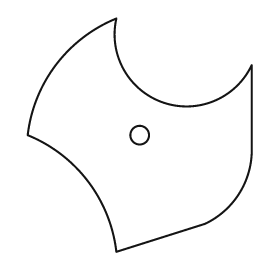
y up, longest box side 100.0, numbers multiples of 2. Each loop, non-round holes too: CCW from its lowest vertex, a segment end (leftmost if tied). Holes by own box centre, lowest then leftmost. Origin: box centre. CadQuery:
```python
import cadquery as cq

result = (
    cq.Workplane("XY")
    .moveTo(-10.0, -50.0)
    .lineTo(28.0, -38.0)
    .threePointArc((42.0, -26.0), (48.0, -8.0))
    .lineTo(48.0, 30.0)
    .threePointArc((10.0, 14.0), (-10.0, 50.0))
    .threePointArc((-36.0, 30.0), (-48.0, 0.0))
    .threePointArc((-22.0, -20.0), (-10.0, -50.0))
    .close()
    .moveTo(0.0, 0.0)
    .circle(4.0)
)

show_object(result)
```